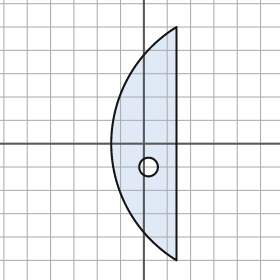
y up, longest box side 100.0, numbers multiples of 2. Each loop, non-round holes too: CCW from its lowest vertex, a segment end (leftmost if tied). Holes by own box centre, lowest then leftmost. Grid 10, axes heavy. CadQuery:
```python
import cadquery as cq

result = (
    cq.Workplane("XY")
    .moveTo(14.0, -50.0)
    .lineTo(14.0, 50.0)
    .threePointArc((-14.0, 0.0), (14.0, -50.0))
    .close()
    .moveTo(2.0, -10.0)
    .circle(4.0)
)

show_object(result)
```